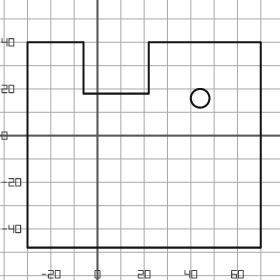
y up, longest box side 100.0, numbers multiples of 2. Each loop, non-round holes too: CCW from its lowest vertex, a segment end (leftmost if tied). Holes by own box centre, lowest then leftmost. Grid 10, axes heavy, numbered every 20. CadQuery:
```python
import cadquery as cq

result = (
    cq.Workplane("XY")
    .moveTo(-30.0, -48.0)
    .lineTo(70.0, -48.0)
    .lineTo(70.0, 40.0)
    .lineTo(22.0, 40.0)
    .lineTo(22.0, 18.0)
    .lineTo(-6.0, 18.0)
    .lineTo(-6.0, 40.0)
    .lineTo(-30.0, 40.0)
    .close()
    .moveTo(44.0, 16.0)
    .circle(4.0)
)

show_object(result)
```